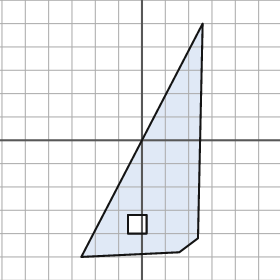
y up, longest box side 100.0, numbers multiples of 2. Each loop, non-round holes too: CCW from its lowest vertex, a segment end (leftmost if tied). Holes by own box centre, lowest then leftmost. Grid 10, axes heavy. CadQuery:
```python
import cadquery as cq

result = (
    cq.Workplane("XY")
    .moveTo(-26.0, -50.0)
    .lineTo(16.0, -48.0)
    .lineTo(24.0, -42.0)
    .lineTo(26.0, 50.0)
    .close()
    .moveTo(-6.0, -40.0)
    .lineTo(2.0, -40.0)
    .lineTo(2.0, -32.0)
    .lineTo(-6.0, -32.0)
    .close()
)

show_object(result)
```